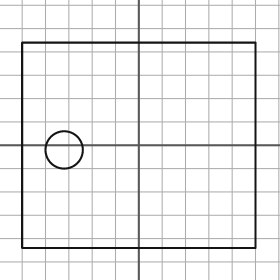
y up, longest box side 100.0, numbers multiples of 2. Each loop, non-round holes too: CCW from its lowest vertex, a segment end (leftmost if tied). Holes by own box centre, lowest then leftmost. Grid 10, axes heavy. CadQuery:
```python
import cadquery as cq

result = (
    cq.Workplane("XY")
    .moveTo(-50.0, -44.0)
    .lineTo(50.0, -44.0)
    .lineTo(50.0, 44.0)
    .lineTo(-50.0, 44.0)
    .close()
    .moveTo(-32.0, -2.0)
    .circle(8.0)
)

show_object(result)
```